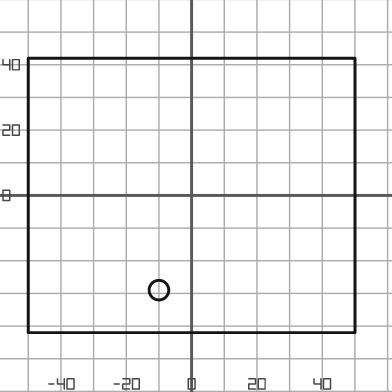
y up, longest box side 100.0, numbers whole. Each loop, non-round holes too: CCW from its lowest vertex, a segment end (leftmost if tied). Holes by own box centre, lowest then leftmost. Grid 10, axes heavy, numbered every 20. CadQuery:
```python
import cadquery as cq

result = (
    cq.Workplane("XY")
    .moveTo(-50.0, -42.0)
    .lineTo(50.0, -42.0)
    .lineTo(50.0, 42.0)
    .lineTo(-50.0, 42.0)
    .close()
    .moveTo(-10.0, -29.0)
    .circle(3.0)
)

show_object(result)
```